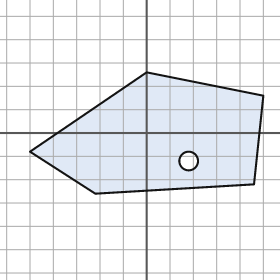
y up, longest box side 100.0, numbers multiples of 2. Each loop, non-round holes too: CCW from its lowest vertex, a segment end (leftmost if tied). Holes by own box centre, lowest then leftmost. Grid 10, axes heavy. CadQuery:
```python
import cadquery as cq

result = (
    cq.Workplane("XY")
    .moveTo(-22.0, -26.0)
    .lineTo(46.0, -22.0)
    .lineTo(50.0, 16.0)
    .lineTo(0.0, 26.0)
    .lineTo(-50.0, -8.0)
    .close()
    .moveTo(18.0, -12.0)
    .circle(4.0)
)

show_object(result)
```